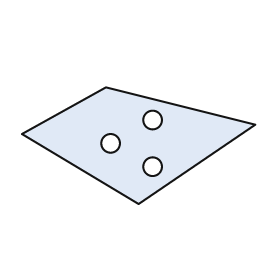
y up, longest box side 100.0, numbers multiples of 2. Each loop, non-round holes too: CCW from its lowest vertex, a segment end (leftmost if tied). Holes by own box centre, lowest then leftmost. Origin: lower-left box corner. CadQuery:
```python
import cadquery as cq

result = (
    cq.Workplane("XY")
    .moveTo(50.0, 0.0)
    .lineTo(100.0, 34.0)
    .lineTo(36.0, 50.0)
    .lineTo(0.0, 30.0)
    .close()
    .moveTo(56.0, 16.0)
    .circle(4.0)
    .moveTo(38.0, 26.0)
    .circle(4.0)
    .moveTo(56.0, 36.0)
    .circle(4.0)
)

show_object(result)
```